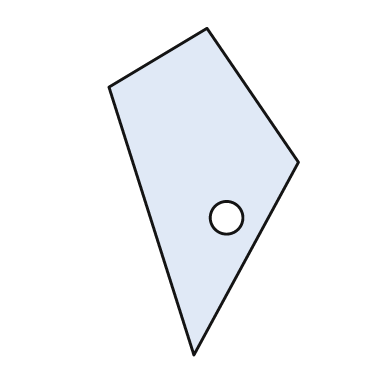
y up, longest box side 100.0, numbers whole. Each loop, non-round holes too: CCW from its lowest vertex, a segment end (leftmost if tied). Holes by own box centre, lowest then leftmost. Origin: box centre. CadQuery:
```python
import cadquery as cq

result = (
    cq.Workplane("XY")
    .moveTo(-3.0, -50.0)
    .lineTo(29.0, 9.0)
    .lineTo(1.0, 50.0)
    .lineTo(-29.0, 32.0)
    .close()
    .moveTo(7.0, -8.0)
    .circle(5.0)
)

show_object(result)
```